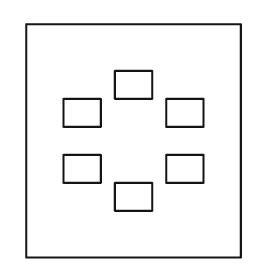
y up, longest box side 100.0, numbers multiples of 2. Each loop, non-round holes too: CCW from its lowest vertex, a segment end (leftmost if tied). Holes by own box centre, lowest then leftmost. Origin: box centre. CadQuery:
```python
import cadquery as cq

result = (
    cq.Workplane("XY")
    .moveTo(-46.0, -50.0)
    .lineTo(46.0, -50.0)
    .lineTo(46.0, 50.0)
    .lineTo(-46.0, 50.0)
    .close()
    .moveTo(-8.0, -30.0)
    .lineTo(8.0, -30.0)
    .lineTo(8.0, -18.0)
    .lineTo(-8.0, -18.0)
    .close()
    .moveTo(-30.0, -18.0)
    .lineTo(-14.0, -18.0)
    .lineTo(-14.0, -6.0)
    .lineTo(-30.0, -6.0)
    .close()
    .moveTo(14.0, -18.0)
    .lineTo(30.0, -18.0)
    .lineTo(30.0, -6.0)
    .lineTo(14.0, -6.0)
    .close()
    .moveTo(-30.0, 6.0)
    .lineTo(-14.0, 6.0)
    .lineTo(-14.0, 18.0)
    .lineTo(-30.0, 18.0)
    .close()
    .moveTo(14.0, 6.0)
    .lineTo(30.0, 6.0)
    .lineTo(30.0, 18.0)
    .lineTo(14.0, 18.0)
    .close()
    .moveTo(-8.0, 18.0)
    .lineTo(8.0, 18.0)
    .lineTo(8.0, 30.0)
    .lineTo(-8.0, 30.0)
    .close()
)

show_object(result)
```